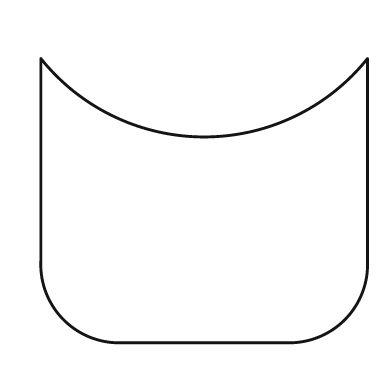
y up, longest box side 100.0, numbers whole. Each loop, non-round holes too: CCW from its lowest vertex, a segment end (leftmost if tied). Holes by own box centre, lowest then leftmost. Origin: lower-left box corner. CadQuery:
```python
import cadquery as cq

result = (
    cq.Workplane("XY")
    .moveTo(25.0, 0.0)
    .lineTo(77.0, 0.0)
    .threePointArc((93.0, 7.0), (100.0, 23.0))
    .lineTo(100.0, 87.0)
    .threePointArc((50.0, 63.0), (0.0, 87.0))
    .lineTo(0.0, 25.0)
    .threePointArc((7.0, 7.0), (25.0, 0.0))
    .close()
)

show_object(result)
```